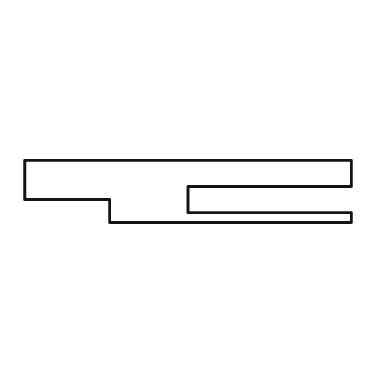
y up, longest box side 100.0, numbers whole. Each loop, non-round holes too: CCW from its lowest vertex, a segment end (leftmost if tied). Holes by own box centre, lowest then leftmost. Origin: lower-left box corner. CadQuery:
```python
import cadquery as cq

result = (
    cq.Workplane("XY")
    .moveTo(26.0, 0.0)
    .lineTo(100.0, 0.0)
    .lineTo(100.0, 3.0)
    .lineTo(50.0, 3.0)
    .lineTo(50.0, 11.0)
    .lineTo(100.0, 11.0)
    .lineTo(100.0, 19.0)
    .lineTo(0.0, 19.0)
    .lineTo(0.0, 7.0)
    .lineTo(26.0, 7.0)
    .close()
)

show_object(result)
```